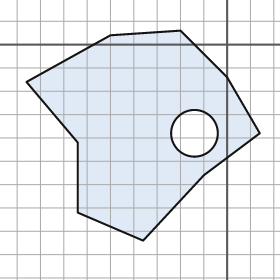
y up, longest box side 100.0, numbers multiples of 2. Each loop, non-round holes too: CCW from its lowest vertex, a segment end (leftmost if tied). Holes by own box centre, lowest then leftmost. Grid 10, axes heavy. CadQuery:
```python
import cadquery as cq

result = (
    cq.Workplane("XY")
    .moveTo(-36.0, -84.0)
    .lineTo(-10.0, -56.0)
    .lineTo(14.0, -38.0)
    .lineTo(0.0, -14.0)
    .lineTo(-20.0, 6.0)
    .lineTo(-50.0, 4.0)
    .lineTo(-86.0, -16.0)
    .lineTo(-64.0, -42.0)
    .lineTo(-64.0, -72.0)
    .close()
    .moveTo(-14.0, -38.0)
    .circle(10.0)
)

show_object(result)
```